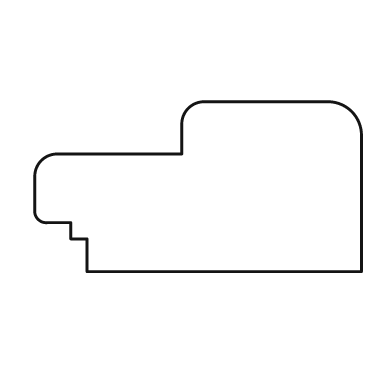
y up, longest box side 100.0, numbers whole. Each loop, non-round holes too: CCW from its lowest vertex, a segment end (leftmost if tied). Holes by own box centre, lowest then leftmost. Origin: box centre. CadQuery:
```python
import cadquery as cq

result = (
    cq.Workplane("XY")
    .moveTo(-34.0, -26.0)
    .lineTo(50.0, -26.0)
    .lineTo(50.0, 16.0)
    .threePointArc((47.0, 23.0), (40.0, 26.0))
    .lineTo(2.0, 26.0)
    .threePointArc((-3.0, 24.0), (-5.0, 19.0))
    .lineTo(-5.0, 10.0)
    .lineTo(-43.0, 10.0)
    .threePointArc((-48.0, 8.0), (-50.0, 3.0))
    .lineTo(-50.0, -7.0)
    .threePointArc((-49.0, -10.0), (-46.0, -11.0))
    .lineTo(-39.0, -11.0)
    .lineTo(-39.0, -16.0)
    .lineTo(-34.0, -16.0)
    .close()
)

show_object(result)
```